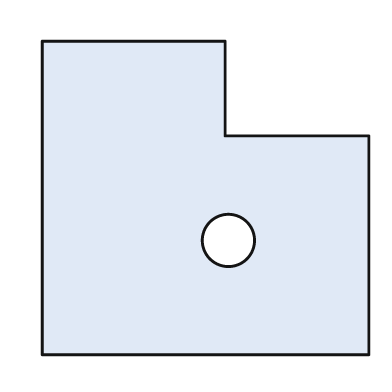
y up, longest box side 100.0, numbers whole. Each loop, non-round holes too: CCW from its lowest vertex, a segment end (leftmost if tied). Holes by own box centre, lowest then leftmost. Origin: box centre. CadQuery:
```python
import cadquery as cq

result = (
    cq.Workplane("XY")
    .moveTo(-50.0, -48.0)
    .lineTo(50.0, -48.0)
    .lineTo(50.0, 19.0)
    .lineTo(6.0, 19.0)
    .lineTo(6.0, 48.0)
    .lineTo(-50.0, 48.0)
    .close()
    .moveTo(7.0, -13.0)
    .circle(8.0)
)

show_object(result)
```